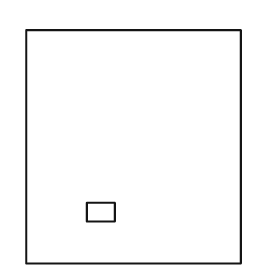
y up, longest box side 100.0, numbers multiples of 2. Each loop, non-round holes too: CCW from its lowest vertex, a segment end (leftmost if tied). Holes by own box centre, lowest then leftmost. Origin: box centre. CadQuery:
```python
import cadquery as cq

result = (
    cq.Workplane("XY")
    .moveTo(-46.0, -50.0)
    .lineTo(46.0, -50.0)
    .lineTo(46.0, 50.0)
    .lineTo(-46.0, 50.0)
    .close()
    .moveTo(-20.0, -32.0)
    .lineTo(-8.0, -32.0)
    .lineTo(-8.0, -24.0)
    .lineTo(-20.0, -24.0)
    .close()
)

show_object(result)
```